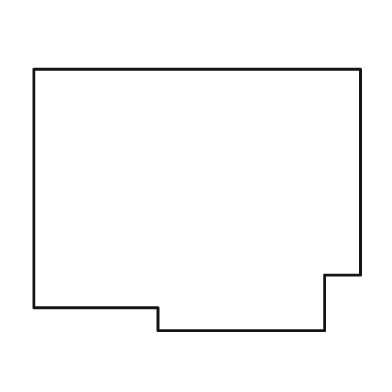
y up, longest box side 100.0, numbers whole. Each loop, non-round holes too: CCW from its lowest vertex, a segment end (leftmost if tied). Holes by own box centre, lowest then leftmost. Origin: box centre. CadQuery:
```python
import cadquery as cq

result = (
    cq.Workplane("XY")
    .moveTo(-12.0, -40.0)
    .lineTo(39.0, -40.0)
    .lineTo(39.0, -23.0)
    .lineTo(50.0, -23.0)
    .lineTo(50.0, 40.0)
    .lineTo(-50.0, 40.0)
    .lineTo(-50.0, -33.0)
    .lineTo(-12.0, -33.0)
    .close()
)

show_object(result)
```